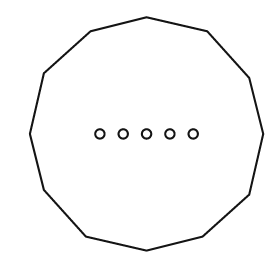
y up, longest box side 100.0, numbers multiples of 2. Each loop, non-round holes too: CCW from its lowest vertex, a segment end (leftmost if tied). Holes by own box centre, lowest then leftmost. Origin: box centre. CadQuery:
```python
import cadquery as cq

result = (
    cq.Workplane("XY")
    .moveTo(0.0, -50.0)
    .lineTo(24.0, -44.0)
    .lineTo(44.0, -26.0)
    .lineTo(50.0, 0.0)
    .lineTo(44.0, 24.0)
    .lineTo(26.0, 44.0)
    .lineTo(0.0, 50.0)
    .lineTo(-24.0, 44.0)
    .lineTo(-44.0, 26.0)
    .lineTo(-50.0, 0.0)
    .lineTo(-44.0, -24.0)
    .lineTo(-26.0, -44.0)
    .close()
    .moveTo(-20.0, 0.0)
    .circle(2.0)
    .moveTo(-10.0, 0.0)
    .circle(2.0)
    .moveTo(0.0, 0.0)
    .circle(2.0)
    .moveTo(10.0, 0.0)
    .circle(2.0)
    .moveTo(20.0, 0.0)
    .circle(2.0)
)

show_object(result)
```